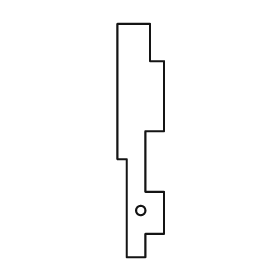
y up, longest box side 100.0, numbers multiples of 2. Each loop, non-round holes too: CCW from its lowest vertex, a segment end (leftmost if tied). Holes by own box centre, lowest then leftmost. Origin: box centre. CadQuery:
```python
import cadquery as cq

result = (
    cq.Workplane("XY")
    .moveTo(-6.0, -50.0)
    .lineTo(2.0, -50.0)
    .lineTo(2.0, -40.0)
    .lineTo(10.0, -40.0)
    .lineTo(10.0, -22.0)
    .lineTo(2.0, -22.0)
    .lineTo(2.0, 4.0)
    .lineTo(10.0, 4.0)
    .lineTo(10.0, 34.0)
    .lineTo(4.0, 34.0)
    .lineTo(4.0, 50.0)
    .lineTo(-10.0, 50.0)
    .lineTo(-10.0, -8.0)
    .lineTo(-6.0, -8.0)
    .close()
    .moveTo(0.0, -30.0)
    .circle(2.0)
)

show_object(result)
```